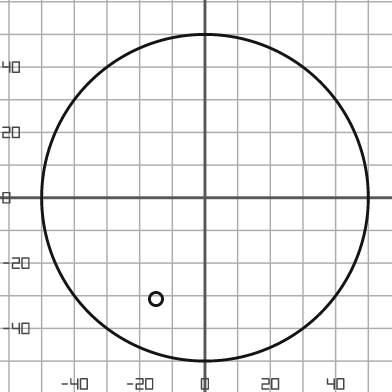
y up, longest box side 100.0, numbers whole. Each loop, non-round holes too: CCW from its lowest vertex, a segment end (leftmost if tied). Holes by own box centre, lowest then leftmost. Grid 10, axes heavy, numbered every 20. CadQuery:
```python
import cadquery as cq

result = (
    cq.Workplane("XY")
    .moveTo(0.0, 0.0)
    .circle(50.0)
    .moveTo(-15.0, -31.0)
    .circle(2.0)
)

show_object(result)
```